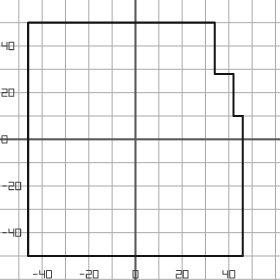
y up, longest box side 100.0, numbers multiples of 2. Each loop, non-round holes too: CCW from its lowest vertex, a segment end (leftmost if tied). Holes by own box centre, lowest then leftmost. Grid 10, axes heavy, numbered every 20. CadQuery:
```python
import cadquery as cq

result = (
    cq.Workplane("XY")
    .moveTo(-46.0, -50.0)
    .lineTo(46.0, -50.0)
    .lineTo(46.0, 10.0)
    .lineTo(42.0, 10.0)
    .lineTo(42.0, 28.0)
    .lineTo(34.0, 28.0)
    .lineTo(34.0, 50.0)
    .lineTo(-46.0, 50.0)
    .close()
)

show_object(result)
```